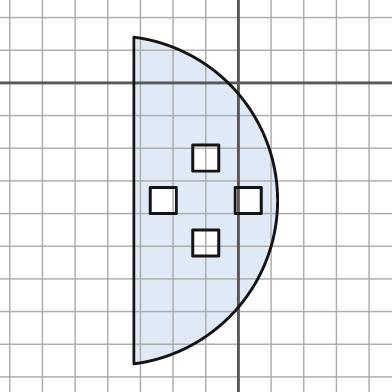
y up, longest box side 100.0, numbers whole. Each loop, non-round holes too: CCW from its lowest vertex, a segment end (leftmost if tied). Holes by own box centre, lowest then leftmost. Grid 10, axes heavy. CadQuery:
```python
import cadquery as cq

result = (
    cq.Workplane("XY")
    .moveTo(-32.0, -86.0)
    .threePointArc((12.0, -36.0), (-32.0, 14.0))
    .close()
    .moveTo(-14.0, -53.0)
    .lineTo(-6.0, -53.0)
    .lineTo(-6.0, -45.0)
    .lineTo(-14.0, -45.0)
    .close()
    .moveTo(-27.0, -40.0)
    .lineTo(-19.0, -40.0)
    .lineTo(-19.0, -32.0)
    .lineTo(-27.0, -32.0)
    .close()
    .moveTo(-1.0, -40.0)
    .lineTo(7.0, -40.0)
    .lineTo(7.0, -32.0)
    .lineTo(-1.0, -32.0)
    .close()
    .moveTo(-14.0, -27.0)
    .lineTo(-6.0, -27.0)
    .lineTo(-6.0, -19.0)
    .lineTo(-14.0, -19.0)
    .close()
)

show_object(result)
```